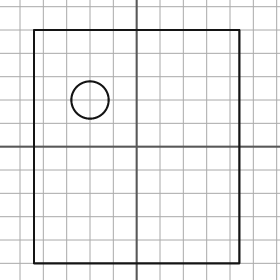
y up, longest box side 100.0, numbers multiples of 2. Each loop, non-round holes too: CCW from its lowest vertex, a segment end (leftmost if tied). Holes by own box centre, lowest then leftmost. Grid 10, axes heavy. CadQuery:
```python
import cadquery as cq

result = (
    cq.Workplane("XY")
    .moveTo(-44.0, -50.0)
    .lineTo(44.0, -50.0)
    .lineTo(44.0, 50.0)
    .lineTo(-44.0, 50.0)
    .close()
    .moveTo(-20.0, 20.0)
    .circle(8.0)
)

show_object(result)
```